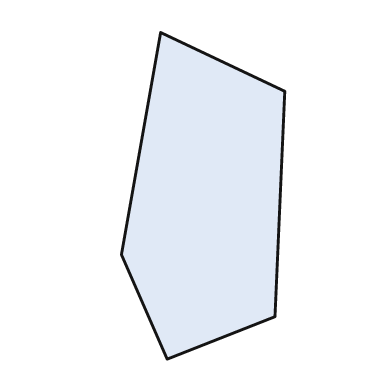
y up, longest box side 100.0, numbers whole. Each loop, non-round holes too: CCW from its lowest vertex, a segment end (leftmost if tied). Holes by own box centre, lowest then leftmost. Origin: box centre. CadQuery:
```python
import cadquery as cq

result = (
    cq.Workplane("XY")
    .moveTo(-11.0, -50.0)
    .lineTo(22.0, -37.0)
    .lineTo(25.0, 32.0)
    .lineTo(-13.0, 50.0)
    .lineTo(-25.0, -18.0)
    .close()
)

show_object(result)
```